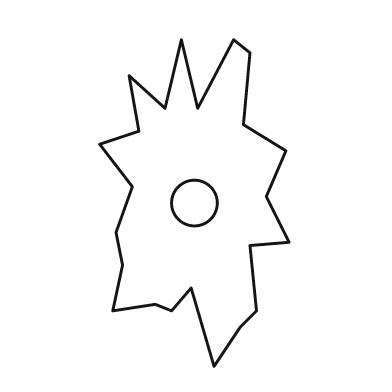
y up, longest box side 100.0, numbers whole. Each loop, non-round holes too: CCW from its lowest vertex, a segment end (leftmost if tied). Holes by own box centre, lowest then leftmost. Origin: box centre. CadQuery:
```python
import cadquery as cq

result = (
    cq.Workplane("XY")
    .moveTo(6.0, -50.0)
    .lineTo(14.0, -38.0)
    .lineTo(19.0, -33.0)
    .lineTo(17.0, -13.0)
    .lineTo(29.0, -12.0)
    .lineTo(22.0, 2.0)
    .lineTo(28.0, 16.0)
    .lineTo(15.0, 24.0)
    .lineTo(17.0, 46.0)
    .lineTo(12.0, 50.0)
    .lineTo(1.0, 29.0)
    .lineTo(-4.0, 50.0)
    .lineTo(-9.0, 29.0)
    .lineTo(-20.0, 39.0)
    .lineTo(-17.0, 22.0)
    .lineTo(-29.0, 18.0)
    .lineTo(-19.0, 5.0)
    .lineTo(-24.0, -9.0)
    .lineTo(-22.0, -19.0)
    .lineTo(-25.0, -33.0)
    .lineTo(-12.0, -31.0)
    .lineTo(-7.0, -33.0)
    .lineTo(-1.0, -26.0)
    .close()
    .moveTo(0.0, 0.0)
    .circle(7.0)
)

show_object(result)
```